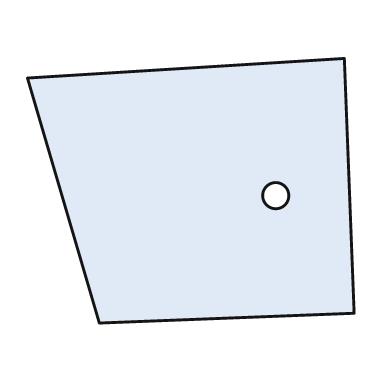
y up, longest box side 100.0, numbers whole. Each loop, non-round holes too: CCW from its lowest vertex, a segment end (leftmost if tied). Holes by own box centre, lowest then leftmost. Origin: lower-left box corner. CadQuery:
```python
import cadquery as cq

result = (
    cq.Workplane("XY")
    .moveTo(22.0, 0.0)
    .lineTo(100.0, 3.0)
    .lineTo(97.0, 81.0)
    .lineTo(0.0, 75.0)
    .close()
    .moveTo(76.0, 39.0)
    .circle(4.0)
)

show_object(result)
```